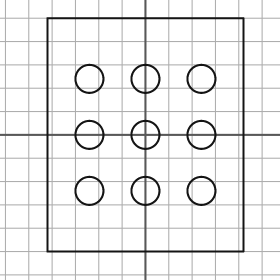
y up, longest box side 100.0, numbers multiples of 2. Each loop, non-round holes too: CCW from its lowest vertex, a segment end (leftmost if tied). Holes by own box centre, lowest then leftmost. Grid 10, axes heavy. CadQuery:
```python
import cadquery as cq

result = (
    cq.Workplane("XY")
    .moveTo(-42.0, -50.0)
    .lineTo(42.0, -50.0)
    .lineTo(42.0, 50.0)
    .lineTo(-42.0, 50.0)
    .close()
    .moveTo(-24.0, -24.0)
    .circle(6.0)
    .moveTo(0.0, -24.0)
    .circle(6.0)
    .moveTo(24.0, -24.0)
    .circle(6.0)
    .moveTo(-24.0, 0.0)
    .circle(6.0)
    .moveTo(0.0, 0.0)
    .circle(6.0)
    .moveTo(24.0, 0.0)
    .circle(6.0)
    .moveTo(-24.0, 24.0)
    .circle(6.0)
    .moveTo(0.0, 24.0)
    .circle(6.0)
    .moveTo(24.0, 24.0)
    .circle(6.0)
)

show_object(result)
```